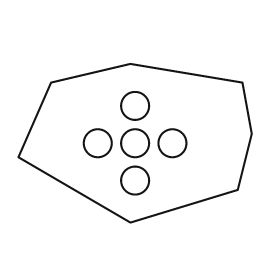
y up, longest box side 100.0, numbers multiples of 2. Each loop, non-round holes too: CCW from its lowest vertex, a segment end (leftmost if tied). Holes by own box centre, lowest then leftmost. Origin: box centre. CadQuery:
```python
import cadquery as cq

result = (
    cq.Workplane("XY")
    .moveTo(-2.0, -34.0)
    .lineTo(44.0, -20.0)
    .lineTo(50.0, 4.0)
    .lineTo(46.0, 26.0)
    .lineTo(-2.0, 34.0)
    .lineTo(-36.0, 26.0)
    .lineTo(-50.0, -6.0)
    .close()
    .moveTo(0.0, -16.0)
    .circle(6.0)
    .moveTo(-16.0, 0.0)
    .circle(6.0)
    .moveTo(0.0, 0.0)
    .circle(6.0)
    .moveTo(16.0, 0.0)
    .circle(6.0)
    .moveTo(0.0, 16.0)
    .circle(6.0)
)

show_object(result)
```